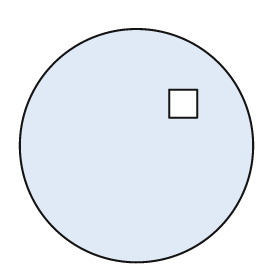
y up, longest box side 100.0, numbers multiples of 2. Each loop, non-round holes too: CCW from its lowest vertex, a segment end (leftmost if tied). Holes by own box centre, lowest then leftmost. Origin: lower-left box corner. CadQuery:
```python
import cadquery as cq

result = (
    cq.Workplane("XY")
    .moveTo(50.0, 50.0)
    .circle(50.0)
    .moveTo(64.0, 62.0)
    .lineTo(76.0, 62.0)
    .lineTo(76.0, 74.0)
    .lineTo(64.0, 74.0)
    .close()
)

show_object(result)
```